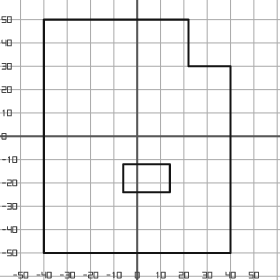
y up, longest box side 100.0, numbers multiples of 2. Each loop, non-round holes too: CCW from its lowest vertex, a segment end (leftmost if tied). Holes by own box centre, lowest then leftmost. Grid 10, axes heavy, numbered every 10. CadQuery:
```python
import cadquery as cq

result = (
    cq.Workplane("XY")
    .moveTo(-40.0, -50.0)
    .lineTo(40.0, -50.0)
    .lineTo(40.0, 30.0)
    .lineTo(22.0, 30.0)
    .lineTo(22.0, 50.0)
    .lineTo(-40.0, 50.0)
    .close()
    .moveTo(-6.0, -24.0)
    .lineTo(14.0, -24.0)
    .lineTo(14.0, -12.0)
    .lineTo(-6.0, -12.0)
    .close()
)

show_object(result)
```